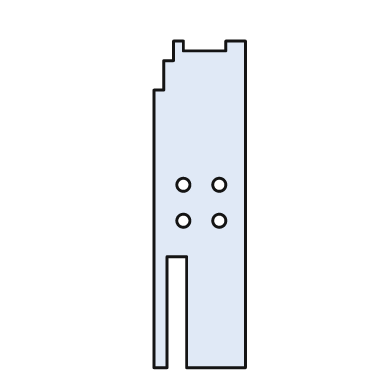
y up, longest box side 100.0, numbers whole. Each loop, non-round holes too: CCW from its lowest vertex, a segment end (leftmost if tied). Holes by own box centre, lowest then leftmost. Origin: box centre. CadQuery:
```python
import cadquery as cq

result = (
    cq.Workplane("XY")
    .moveTo(-14.0, -50.0)
    .lineTo(-10.0, -50.0)
    .lineTo(-10.0, -16.0)
    .lineTo(-4.0, -16.0)
    .lineTo(-4.0, -50.0)
    .lineTo(14.0, -50.0)
    .lineTo(14.0, 50.0)
    .lineTo(8.0, 50.0)
    .lineTo(8.0, 47.0)
    .lineTo(-5.0, 47.0)
    .lineTo(-5.0, 50.0)
    .lineTo(-8.0, 50.0)
    .lineTo(-8.0, 44.0)
    .lineTo(-11.0, 44.0)
    .lineTo(-11.0, 35.0)
    .lineTo(-14.0, 35.0)
    .close()
    .moveTo(-5.0, -5.0)
    .circle(2.0)
    .moveTo(6.0, -5.0)
    .circle(2.0)
    .moveTo(-5.0, 6.0)
    .circle(2.0)
    .moveTo(6.0, 6.0)
    .circle(2.0)
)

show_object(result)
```